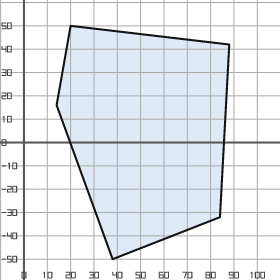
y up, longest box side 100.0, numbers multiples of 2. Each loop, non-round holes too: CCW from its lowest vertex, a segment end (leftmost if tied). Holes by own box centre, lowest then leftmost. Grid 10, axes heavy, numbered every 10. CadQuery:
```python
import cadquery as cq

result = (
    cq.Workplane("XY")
    .moveTo(38.0, -50.0)
    .lineTo(84.0, -32.0)
    .lineTo(88.0, 42.0)
    .lineTo(20.0, 50.0)
    .lineTo(14.0, 16.0)
    .close()
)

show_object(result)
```